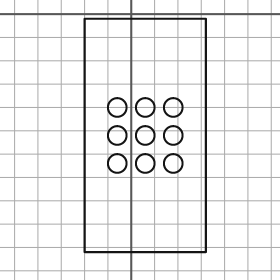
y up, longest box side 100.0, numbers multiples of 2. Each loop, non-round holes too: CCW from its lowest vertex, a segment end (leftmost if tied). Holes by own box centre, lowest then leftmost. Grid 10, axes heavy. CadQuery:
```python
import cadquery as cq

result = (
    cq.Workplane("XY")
    .moveTo(-20.0, -102.0)
    .lineTo(32.0, -102.0)
    .lineTo(32.0, -2.0)
    .lineTo(-20.0, -2.0)
    .close()
    .moveTo(-6.0, -64.0)
    .circle(4.0)
    .moveTo(6.0, -64.0)
    .circle(4.0)
    .moveTo(18.0, -64.0)
    .circle(4.0)
    .moveTo(-6.0, -52.0)
    .circle(4.0)
    .moveTo(6.0, -52.0)
    .circle(4.0)
    .moveTo(18.0, -52.0)
    .circle(4.0)
    .moveTo(-6.0, -40.0)
    .circle(4.0)
    .moveTo(6.0, -40.0)
    .circle(4.0)
    .moveTo(18.0, -40.0)
    .circle(4.0)
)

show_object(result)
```